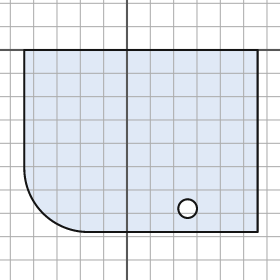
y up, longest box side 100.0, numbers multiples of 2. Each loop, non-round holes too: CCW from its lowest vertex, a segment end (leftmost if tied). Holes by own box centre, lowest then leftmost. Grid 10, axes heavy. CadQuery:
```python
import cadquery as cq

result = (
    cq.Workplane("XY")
    .moveTo(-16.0, -78.0)
    .lineTo(56.0, -78.0)
    .lineTo(56.0, 0.0)
    .lineTo(-44.0, 0.0)
    .lineTo(-44.0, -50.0)
    .threePointArc((-36.0, -70.0), (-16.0, -78.0))
    .close()
    .moveTo(26.0, -68.0)
    .circle(4.0)
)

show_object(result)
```